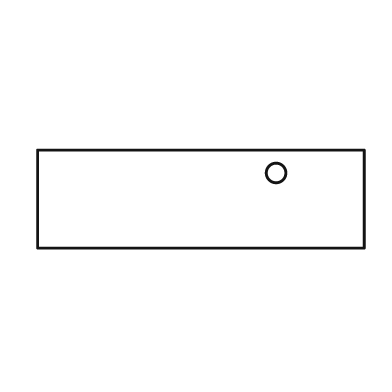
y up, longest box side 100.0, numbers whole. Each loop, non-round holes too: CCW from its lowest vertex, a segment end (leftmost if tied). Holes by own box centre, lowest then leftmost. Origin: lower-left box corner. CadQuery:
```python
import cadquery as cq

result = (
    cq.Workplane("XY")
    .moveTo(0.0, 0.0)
    .lineTo(100.0, 0.0)
    .lineTo(100.0, 30.0)
    .lineTo(0.0, 30.0)
    .close()
    .moveTo(73.0, 23.0)
    .circle(3.0)
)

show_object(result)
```